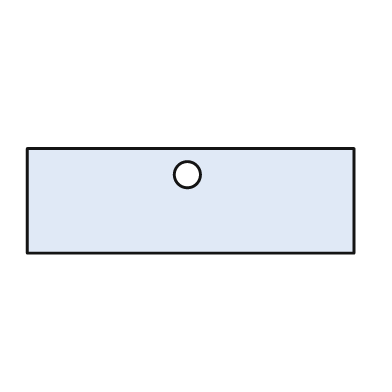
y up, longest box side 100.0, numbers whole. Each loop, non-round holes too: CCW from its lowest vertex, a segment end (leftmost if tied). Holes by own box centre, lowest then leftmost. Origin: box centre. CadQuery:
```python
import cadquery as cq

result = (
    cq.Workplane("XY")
    .moveTo(-50.0, -16.0)
    .lineTo(50.0, -16.0)
    .lineTo(50.0, 16.0)
    .lineTo(-50.0, 16.0)
    .close()
    .moveTo(-1.0, 8.0)
    .circle(4.0)
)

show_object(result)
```